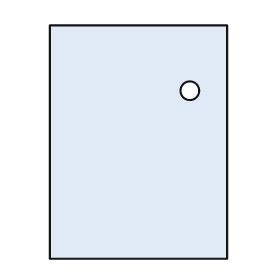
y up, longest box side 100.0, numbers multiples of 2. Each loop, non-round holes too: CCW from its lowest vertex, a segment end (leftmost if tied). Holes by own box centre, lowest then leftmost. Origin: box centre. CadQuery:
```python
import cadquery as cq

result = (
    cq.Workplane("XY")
    .moveTo(-38.0, -50.0)
    .lineTo(38.0, -50.0)
    .lineTo(38.0, 50.0)
    .lineTo(-38.0, 50.0)
    .close()
    .moveTo(22.0, 22.0)
    .circle(4.0)
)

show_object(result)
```